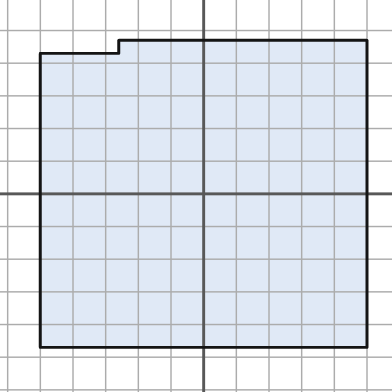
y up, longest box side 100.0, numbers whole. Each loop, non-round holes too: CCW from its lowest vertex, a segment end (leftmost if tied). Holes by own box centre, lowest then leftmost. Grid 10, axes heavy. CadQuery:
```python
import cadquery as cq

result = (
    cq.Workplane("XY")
    .moveTo(-50.0, -47.0)
    .lineTo(50.0, -47.0)
    .lineTo(50.0, 47.0)
    .lineTo(-26.0, 47.0)
    .lineTo(-26.0, 43.0)
    .lineTo(-50.0, 43.0)
    .close()
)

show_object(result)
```